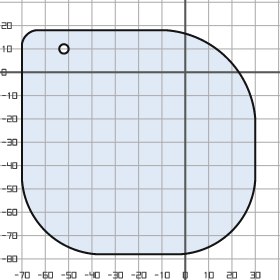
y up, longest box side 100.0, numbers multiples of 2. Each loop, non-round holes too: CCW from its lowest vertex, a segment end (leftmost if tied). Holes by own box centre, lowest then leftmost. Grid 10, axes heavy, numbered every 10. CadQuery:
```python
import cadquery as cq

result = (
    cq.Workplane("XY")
    .moveTo(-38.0, -78.0)
    .lineTo(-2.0, -78.0)
    .threePointArc((20.0, -68.0), (30.0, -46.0))
    .lineTo(30.0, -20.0)
    .threePointArc((18.0, 6.0), (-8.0, 18.0))
    .lineTo(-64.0, 18.0)
    .threePointArc((-68.0, 16.0), (-70.0, 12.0))
    .lineTo(-70.0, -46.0)
    .threePointArc((-60.0, -68.0), (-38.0, -78.0))
    .close()
    .moveTo(-52.0, 10.0)
    .circle(2.0)
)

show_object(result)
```